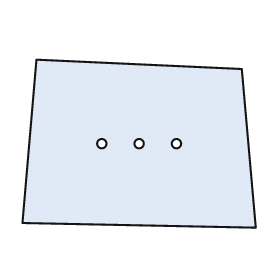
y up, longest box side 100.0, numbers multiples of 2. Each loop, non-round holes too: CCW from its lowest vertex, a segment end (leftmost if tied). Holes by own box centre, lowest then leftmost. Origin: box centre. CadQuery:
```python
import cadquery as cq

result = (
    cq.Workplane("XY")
    .moveTo(50.0, -36.0)
    .lineTo(44.0, 32.0)
    .lineTo(-44.0, 36.0)
    .lineTo(-50.0, -34.0)
    .close()
    .moveTo(-16.0, 0.0)
    .circle(2.0)
    .moveTo(0.0, 0.0)
    .circle(2.0)
    .moveTo(16.0, 0.0)
    .circle(2.0)
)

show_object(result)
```